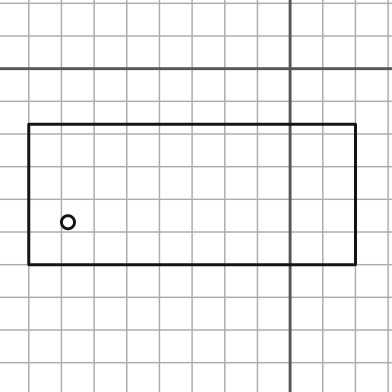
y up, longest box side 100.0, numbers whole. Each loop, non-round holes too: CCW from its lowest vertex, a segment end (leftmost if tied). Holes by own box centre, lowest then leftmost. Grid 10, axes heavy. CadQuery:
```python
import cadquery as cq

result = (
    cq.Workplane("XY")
    .moveTo(-80.0, -60.0)
    .lineTo(20.0, -60.0)
    .lineTo(20.0, -17.0)
    .lineTo(-80.0, -17.0)
    .close()
    .moveTo(-68.0, -47.0)
    .circle(2.0)
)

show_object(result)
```